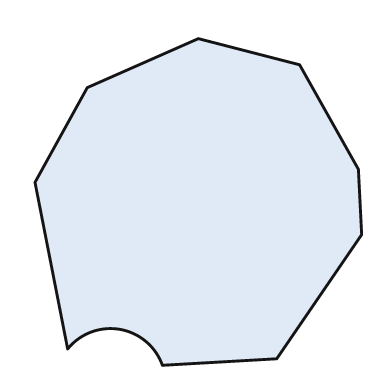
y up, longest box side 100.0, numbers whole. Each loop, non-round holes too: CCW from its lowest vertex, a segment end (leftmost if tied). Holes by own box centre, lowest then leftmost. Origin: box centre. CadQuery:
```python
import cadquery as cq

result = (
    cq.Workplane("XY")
    .moveTo(-11.0, -50.0)
    .lineTo(24.0, -48.0)
    .lineTo(50.0, -10.0)
    .lineTo(49.0, 10.0)
    .lineTo(31.0, 42.0)
    .lineTo(0.0, 50.0)
    .lineTo(-34.0, 35.0)
    .lineTo(-50.0, 6.0)
    .lineTo(-40.0, -45.0)
    .threePointArc((-24.0, -39.0), (-11.0, -50.0))
    .close()
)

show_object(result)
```